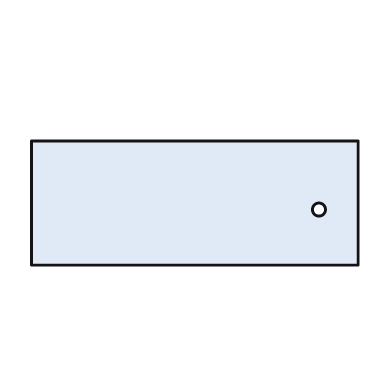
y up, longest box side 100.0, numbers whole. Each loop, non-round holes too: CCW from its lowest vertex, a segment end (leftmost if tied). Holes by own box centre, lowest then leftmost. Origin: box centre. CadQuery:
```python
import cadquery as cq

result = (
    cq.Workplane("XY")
    .moveTo(-50.0, -19.0)
    .lineTo(50.0, -19.0)
    .lineTo(50.0, 19.0)
    .lineTo(-50.0, 19.0)
    .close()
    .moveTo(38.0, -2.0)
    .circle(2.0)
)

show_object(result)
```